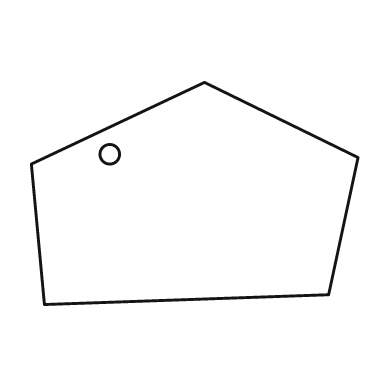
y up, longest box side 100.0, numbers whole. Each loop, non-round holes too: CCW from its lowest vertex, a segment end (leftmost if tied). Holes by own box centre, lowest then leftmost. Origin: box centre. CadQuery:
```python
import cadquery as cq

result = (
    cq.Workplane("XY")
    .moveTo(-46.0, -34.0)
    .lineTo(41.0, -31.0)
    .lineTo(50.0, 11.0)
    .lineTo(3.0, 34.0)
    .lineTo(-50.0, 9.0)
    .close()
    .moveTo(-26.0, 12.0)
    .circle(3.0)
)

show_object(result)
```